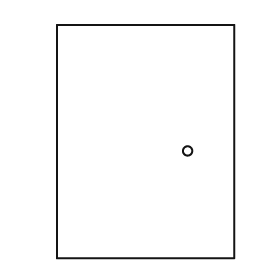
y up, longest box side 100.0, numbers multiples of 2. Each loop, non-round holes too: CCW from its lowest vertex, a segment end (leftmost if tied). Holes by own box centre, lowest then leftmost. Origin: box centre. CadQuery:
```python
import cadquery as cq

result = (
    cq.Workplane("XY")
    .moveTo(-38.0, -50.0)
    .lineTo(38.0, -50.0)
    .lineTo(38.0, 50.0)
    .lineTo(-38.0, 50.0)
    .close()
    .moveTo(18.0, -4.0)
    .circle(2.0)
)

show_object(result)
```